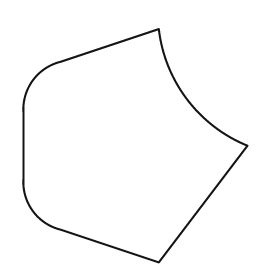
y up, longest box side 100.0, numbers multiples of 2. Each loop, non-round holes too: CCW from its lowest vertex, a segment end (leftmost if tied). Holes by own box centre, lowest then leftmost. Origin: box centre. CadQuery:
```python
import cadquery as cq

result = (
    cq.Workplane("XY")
    .moveTo(10.0, -50.0)
    .lineTo(48.0, 0.0)
    .threePointArc((22.0, 20.0), (10.0, 50.0))
    .lineTo(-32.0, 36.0)
    .threePointArc((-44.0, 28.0), (-48.0, 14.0))
    .lineTo(-48.0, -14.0)
    .threePointArc((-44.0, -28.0), (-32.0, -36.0))
    .close()
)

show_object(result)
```